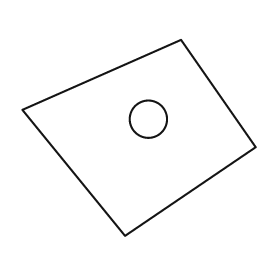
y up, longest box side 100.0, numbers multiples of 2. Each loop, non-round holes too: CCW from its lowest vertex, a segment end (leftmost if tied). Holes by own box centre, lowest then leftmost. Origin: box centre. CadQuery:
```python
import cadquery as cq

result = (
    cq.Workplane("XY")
    .moveTo(-6.0, -42.0)
    .lineTo(50.0, -4.0)
    .lineTo(18.0, 42.0)
    .lineTo(-50.0, 12.0)
    .close()
    .moveTo(4.0, 8.0)
    .circle(8.0)
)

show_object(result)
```